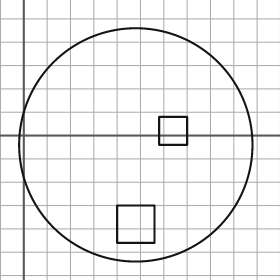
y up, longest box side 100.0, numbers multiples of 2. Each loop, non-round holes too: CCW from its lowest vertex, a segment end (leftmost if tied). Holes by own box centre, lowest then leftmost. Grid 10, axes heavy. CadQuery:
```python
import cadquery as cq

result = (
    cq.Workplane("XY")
    .moveTo(48.0, -4.0)
    .circle(50.0)
    .moveTo(40.0, -46.0)
    .lineTo(56.0, -46.0)
    .lineTo(56.0, -30.0)
    .lineTo(40.0, -30.0)
    .close()
    .moveTo(58.0, -4.0)
    .lineTo(70.0, -4.0)
    .lineTo(70.0, 8.0)
    .lineTo(58.0, 8.0)
    .close()
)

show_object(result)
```